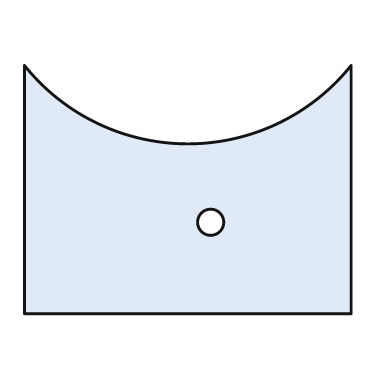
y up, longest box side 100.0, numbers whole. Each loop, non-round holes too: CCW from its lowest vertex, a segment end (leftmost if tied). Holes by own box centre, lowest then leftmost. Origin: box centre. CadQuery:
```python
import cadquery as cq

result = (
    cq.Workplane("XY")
    .moveTo(-50.0, -38.0)
    .lineTo(50.0, -38.0)
    .lineTo(50.0, 38.0)
    .threePointArc((0.0, 14.0), (-50.0, 38.0))
    .close()
    .moveTo(7.0, -10.0)
    .circle(4.0)
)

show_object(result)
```